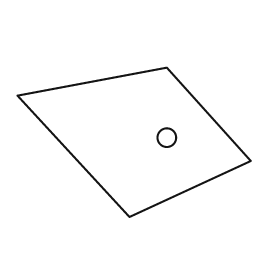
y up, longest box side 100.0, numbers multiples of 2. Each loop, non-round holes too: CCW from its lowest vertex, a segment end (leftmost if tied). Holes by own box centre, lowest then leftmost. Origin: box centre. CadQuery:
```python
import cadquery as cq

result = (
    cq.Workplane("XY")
    .moveTo(-2.0, -32.0)
    .lineTo(50.0, -8.0)
    .lineTo(14.0, 32.0)
    .lineTo(-50.0, 20.0)
    .close()
    .moveTo(14.0, 2.0)
    .circle(4.0)
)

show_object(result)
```